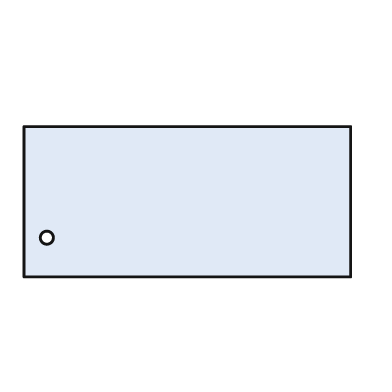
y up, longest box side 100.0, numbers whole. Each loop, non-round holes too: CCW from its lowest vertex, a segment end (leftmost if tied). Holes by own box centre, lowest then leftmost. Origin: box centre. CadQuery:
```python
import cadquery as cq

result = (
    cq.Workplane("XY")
    .moveTo(-50.0, -23.0)
    .lineTo(50.0, -23.0)
    .lineTo(50.0, 23.0)
    .lineTo(-50.0, 23.0)
    .close()
    .moveTo(-43.0, -11.0)
    .circle(2.0)
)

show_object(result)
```